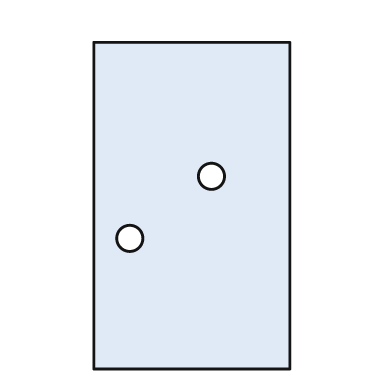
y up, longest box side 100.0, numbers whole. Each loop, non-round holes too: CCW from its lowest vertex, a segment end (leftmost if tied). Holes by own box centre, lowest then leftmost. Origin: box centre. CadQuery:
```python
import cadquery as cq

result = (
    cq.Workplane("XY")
    .moveTo(-30.0, -50.0)
    .lineTo(30.0, -50.0)
    .lineTo(30.0, 50.0)
    .lineTo(-30.0, 50.0)
    .close()
    .moveTo(-19.0, -10.0)
    .circle(4.0)
    .moveTo(6.0, 9.0)
    .circle(4.0)
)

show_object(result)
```